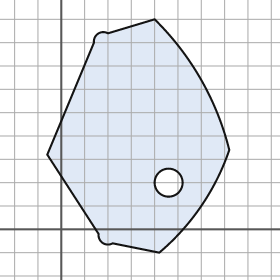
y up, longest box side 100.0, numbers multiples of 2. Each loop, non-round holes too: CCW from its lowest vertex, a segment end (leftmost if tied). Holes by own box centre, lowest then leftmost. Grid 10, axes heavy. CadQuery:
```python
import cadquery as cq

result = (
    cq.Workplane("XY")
    .moveTo(42.0, -10.0)
    .threePointArc((60.0, 10.0), (72.0, 34.0))
    .threePointArc((60.0, 64.0), (40.0, 90.0))
    .lineTo(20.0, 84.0)
    .threePointArc((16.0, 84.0), (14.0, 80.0))
    .lineTo(-6.0, 32.0)
    .lineTo(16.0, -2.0)
    .threePointArc((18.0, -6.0), (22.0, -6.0))
    .close()
    .moveTo(46.0, 20.0)
    .circle(6.0)
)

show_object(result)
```